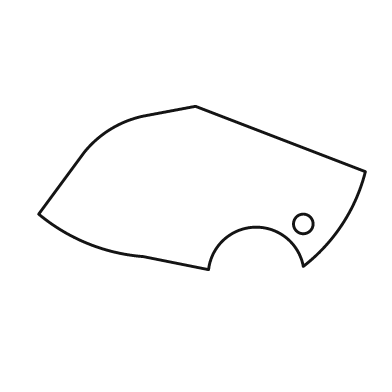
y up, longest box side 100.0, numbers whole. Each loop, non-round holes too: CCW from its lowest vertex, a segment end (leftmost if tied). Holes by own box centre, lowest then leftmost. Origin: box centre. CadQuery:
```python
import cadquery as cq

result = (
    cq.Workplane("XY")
    .moveTo(2.0, -25.0)
    .threePointArc((16.0, -12.0), (31.0, -24.0))
    .threePointArc((43.0, -11.0), (50.0, 5.0))
    .lineTo(-2.0, 25.0)
    .lineTo(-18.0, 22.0)
    .threePointArc((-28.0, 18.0), (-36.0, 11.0))
    .lineTo(-50.0, -8.0)
    .threePointArc((-35.0, -17.0), (-18.0, -21.0))
    .close()
    .moveTo(31.0, -11.0)
    .circle(3.0)
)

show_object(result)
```